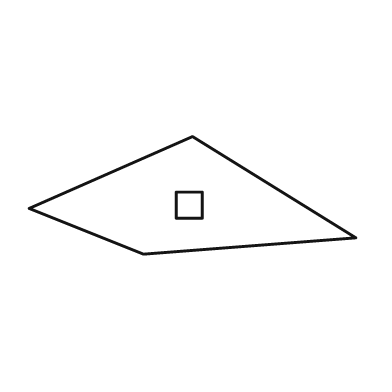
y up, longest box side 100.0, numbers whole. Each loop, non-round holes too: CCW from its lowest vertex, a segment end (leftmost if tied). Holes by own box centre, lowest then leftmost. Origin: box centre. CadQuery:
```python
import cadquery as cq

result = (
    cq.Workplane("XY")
    .moveTo(-15.0, -18.0)
    .lineTo(50.0, -13.0)
    .lineTo(0.0, 18.0)
    .lineTo(-50.0, -4.0)
    .close()
    .moveTo(-5.0, -7.0)
    .lineTo(3.0, -7.0)
    .lineTo(3.0, 1.0)
    .lineTo(-5.0, 1.0)
    .close()
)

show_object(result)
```